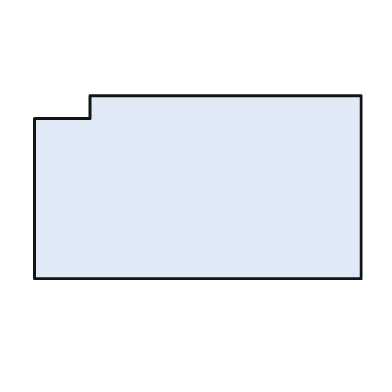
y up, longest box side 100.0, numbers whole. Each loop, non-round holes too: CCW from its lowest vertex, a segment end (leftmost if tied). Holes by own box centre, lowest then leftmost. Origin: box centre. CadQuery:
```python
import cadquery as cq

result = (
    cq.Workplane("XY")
    .moveTo(-50.0, -28.0)
    .lineTo(50.0, -28.0)
    .lineTo(50.0, 28.0)
    .lineTo(-33.0, 28.0)
    .lineTo(-33.0, 21.0)
    .lineTo(-50.0, 21.0)
    .close()
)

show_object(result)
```